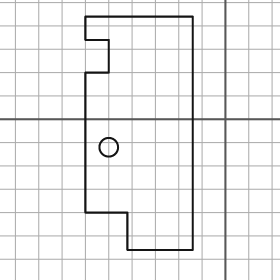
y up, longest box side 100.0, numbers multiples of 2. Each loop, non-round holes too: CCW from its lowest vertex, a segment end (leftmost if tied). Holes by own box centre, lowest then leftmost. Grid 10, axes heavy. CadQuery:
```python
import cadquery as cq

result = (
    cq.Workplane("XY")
    .moveTo(-42.0, -56.0)
    .lineTo(-14.0, -56.0)
    .lineTo(-14.0, 44.0)
    .lineTo(-60.0, 44.0)
    .lineTo(-60.0, 34.0)
    .lineTo(-50.0, 34.0)
    .lineTo(-50.0, 20.0)
    .lineTo(-60.0, 20.0)
    .lineTo(-60.0, -40.0)
    .lineTo(-42.0, -40.0)
    .close()
    .moveTo(-50.0, -12.0)
    .circle(4.0)
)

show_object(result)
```